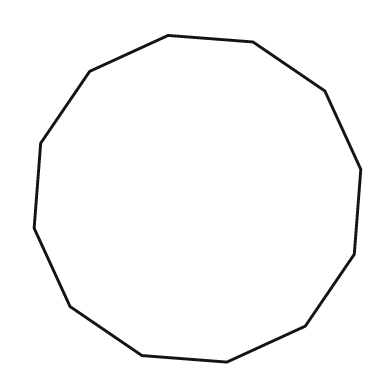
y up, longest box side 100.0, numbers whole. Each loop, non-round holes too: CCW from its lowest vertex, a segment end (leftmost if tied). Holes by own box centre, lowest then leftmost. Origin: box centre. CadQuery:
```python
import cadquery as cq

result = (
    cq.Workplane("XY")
    .moveTo(9.0, -50.0)
    .lineTo(33.0, -39.0)
    .lineTo(48.0, -17.0)
    .lineTo(50.0, 9.0)
    .lineTo(39.0, 33.0)
    .lineTo(17.0, 48.0)
    .lineTo(-9.0, 50.0)
    .lineTo(-33.0, 39.0)
    .lineTo(-48.0, 17.0)
    .lineTo(-50.0, -9.0)
    .lineTo(-39.0, -33.0)
    .lineTo(-17.0, -48.0)
    .close()
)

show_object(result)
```